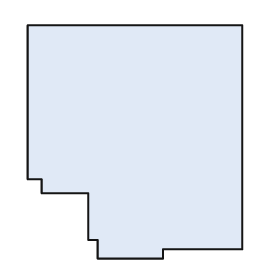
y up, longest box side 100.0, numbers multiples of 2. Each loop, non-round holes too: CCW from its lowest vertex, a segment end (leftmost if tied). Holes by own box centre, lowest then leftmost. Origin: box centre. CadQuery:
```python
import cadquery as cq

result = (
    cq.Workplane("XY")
    .moveTo(-16.0, -50.0)
    .lineTo(12.0, -50.0)
    .lineTo(12.0, -46.0)
    .lineTo(46.0, -46.0)
    .lineTo(46.0, 50.0)
    .lineTo(-46.0, 50.0)
    .lineTo(-46.0, -16.0)
    .lineTo(-40.0, -16.0)
    .lineTo(-40.0, -22.0)
    .lineTo(-20.0, -22.0)
    .lineTo(-20.0, -42.0)
    .lineTo(-16.0, -42.0)
    .close()
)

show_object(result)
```